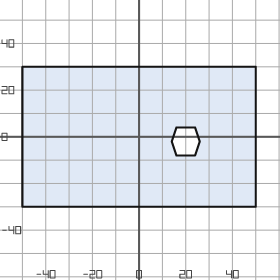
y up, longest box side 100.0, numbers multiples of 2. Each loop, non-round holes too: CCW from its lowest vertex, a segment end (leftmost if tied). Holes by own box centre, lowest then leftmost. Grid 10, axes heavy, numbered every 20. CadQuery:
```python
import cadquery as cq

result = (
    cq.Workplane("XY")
    .moveTo(-50.0, -30.0)
    .lineTo(50.0, -30.0)
    .lineTo(50.0, 30.0)
    .lineTo(-50.0, 30.0)
    .close()
    .moveTo(16.0, -8.0)
    .lineTo(24.0, -8.0)
    .lineTo(26.0, -2.0)
    .lineTo(24.0, 4.0)
    .lineTo(16.0, 4.0)
    .lineTo(14.0, -2.0)
    .close()
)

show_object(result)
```